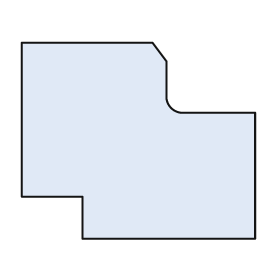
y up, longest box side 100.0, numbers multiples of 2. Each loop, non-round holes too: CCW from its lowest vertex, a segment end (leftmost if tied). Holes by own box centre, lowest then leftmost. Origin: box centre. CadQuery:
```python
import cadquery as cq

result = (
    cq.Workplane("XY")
    .moveTo(-24.0, -42.0)
    .lineTo(50.0, -42.0)
    .lineTo(50.0, 12.0)
    .lineTo(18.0, 12.0)
    .threePointArc((14.0, 14.0), (12.0, 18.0))
    .lineTo(12.0, 34.0)
    .lineTo(6.0, 42.0)
    .lineTo(-50.0, 42.0)
    .lineTo(-50.0, -24.0)
    .lineTo(-24.0, -24.0)
    .close()
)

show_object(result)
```